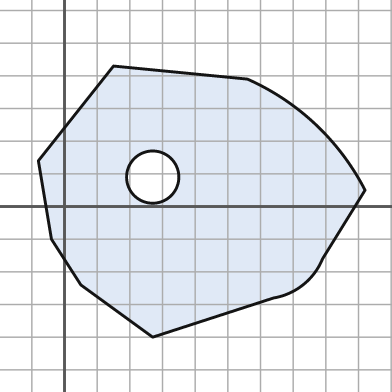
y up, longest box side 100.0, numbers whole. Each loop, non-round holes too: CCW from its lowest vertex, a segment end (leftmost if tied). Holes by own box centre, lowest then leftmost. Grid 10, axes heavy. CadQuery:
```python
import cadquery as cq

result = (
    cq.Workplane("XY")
    .moveTo(27.0, -40.0)
    .lineTo(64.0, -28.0)
    .threePointArc((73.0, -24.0), (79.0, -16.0))
    .lineTo(92.0, 5.0)
    .threePointArc((77.0, 25.0), (56.0, 39.0))
    .lineTo(15.0, 43.0)
    .lineTo(-8.0, 14.0)
    .lineTo(-4.0, -10.0)
    .lineTo(5.0, -24.0)
    .close()
    .moveTo(27.0, 9.0)
    .circle(8.0)
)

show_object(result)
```